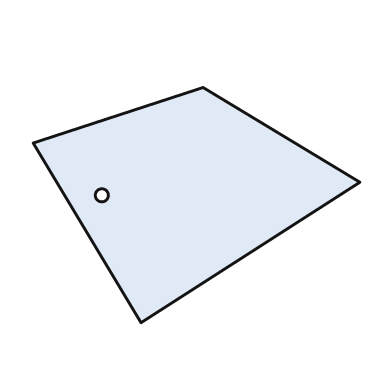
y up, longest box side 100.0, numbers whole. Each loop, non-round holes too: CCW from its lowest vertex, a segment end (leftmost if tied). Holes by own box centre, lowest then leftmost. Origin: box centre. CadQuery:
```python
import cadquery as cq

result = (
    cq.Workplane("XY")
    .moveTo(-17.0, -36.0)
    .lineTo(50.0, 7.0)
    .lineTo(2.0, 36.0)
    .lineTo(-50.0, 19.0)
    .close()
    .moveTo(-29.0, 3.0)
    .circle(2.0)
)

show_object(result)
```